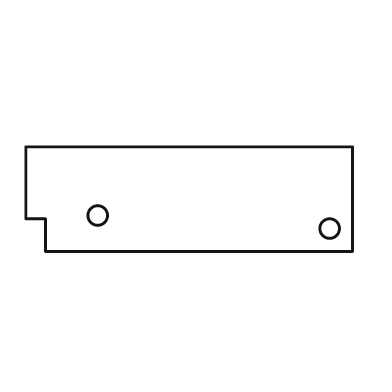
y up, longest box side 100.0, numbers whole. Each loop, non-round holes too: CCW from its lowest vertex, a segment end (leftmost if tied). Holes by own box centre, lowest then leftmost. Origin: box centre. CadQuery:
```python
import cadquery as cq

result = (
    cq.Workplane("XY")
    .moveTo(-44.0, -16.0)
    .lineTo(50.0, -16.0)
    .lineTo(50.0, 16.0)
    .lineTo(-50.0, 16.0)
    .lineTo(-50.0, -6.0)
    .lineTo(-44.0, -6.0)
    .close()
    .moveTo(43.0, -9.0)
    .circle(3.0)
    .moveTo(-28.0, -5.0)
    .circle(3.0)
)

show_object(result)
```